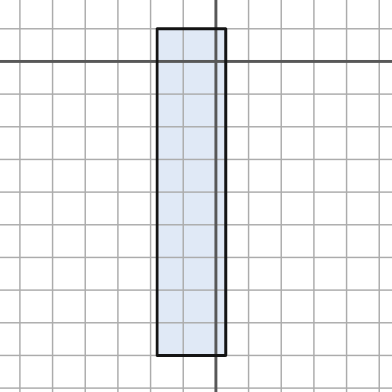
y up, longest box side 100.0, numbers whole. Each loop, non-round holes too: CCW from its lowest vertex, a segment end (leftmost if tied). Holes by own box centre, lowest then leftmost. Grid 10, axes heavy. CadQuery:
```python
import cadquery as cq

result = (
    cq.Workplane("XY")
    .moveTo(-18.0, -90.0)
    .lineTo(3.0, -90.0)
    .lineTo(3.0, 10.0)
    .lineTo(-18.0, 10.0)
    .close()
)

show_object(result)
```